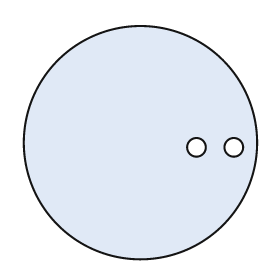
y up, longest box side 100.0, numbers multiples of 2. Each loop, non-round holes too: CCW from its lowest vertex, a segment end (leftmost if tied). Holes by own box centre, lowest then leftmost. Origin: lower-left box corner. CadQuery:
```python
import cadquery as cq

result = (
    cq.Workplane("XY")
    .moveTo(50.0, 50.0)
    .circle(50.0)
    .moveTo(74.0, 48.0)
    .circle(4.0)
    .moveTo(90.0, 48.0)
    .circle(4.0)
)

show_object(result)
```